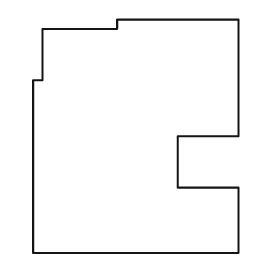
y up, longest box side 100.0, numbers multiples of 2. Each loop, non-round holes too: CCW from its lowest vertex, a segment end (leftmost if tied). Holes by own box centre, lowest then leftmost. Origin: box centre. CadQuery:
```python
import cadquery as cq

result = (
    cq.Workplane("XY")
    .moveTo(-44.0, -50.0)
    .lineTo(44.0, -50.0)
    .lineTo(44.0, -22.0)
    .lineTo(18.0, -22.0)
    .lineTo(18.0, 0.0)
    .lineTo(44.0, 0.0)
    .lineTo(44.0, 50.0)
    .lineTo(-8.0, 50.0)
    .lineTo(-8.0, 46.0)
    .lineTo(-40.0, 46.0)
    .lineTo(-40.0, 24.0)
    .lineTo(-44.0, 24.0)
    .close()
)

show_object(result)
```